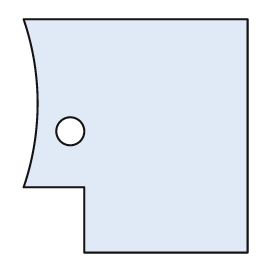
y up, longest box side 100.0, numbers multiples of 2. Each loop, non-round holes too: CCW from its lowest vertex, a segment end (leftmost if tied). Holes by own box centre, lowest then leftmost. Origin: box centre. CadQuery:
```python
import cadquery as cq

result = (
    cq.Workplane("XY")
    .moveTo(-22.0, -50.0)
    .lineTo(48.0, -50.0)
    .lineTo(48.0, 50.0)
    .lineTo(-48.0, 50.0)
    .threePointArc((-42.0, 14.0), (-48.0, -22.0))
    .lineTo(-22.0, -22.0)
    .close()
    .moveTo(-28.0, 2.0)
    .circle(6.0)
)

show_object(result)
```